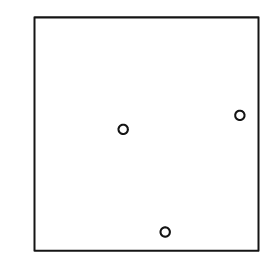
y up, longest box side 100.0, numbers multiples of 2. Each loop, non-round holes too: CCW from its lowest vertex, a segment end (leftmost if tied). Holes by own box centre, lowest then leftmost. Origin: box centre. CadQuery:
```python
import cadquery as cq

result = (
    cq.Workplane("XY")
    .moveTo(-48.0, -50.0)
    .lineTo(48.0, -50.0)
    .lineTo(48.0, 50.0)
    .lineTo(-48.0, 50.0)
    .close()
    .moveTo(8.0, -42.0)
    .circle(2.0)
    .moveTo(-10.0, 2.0)
    .circle(2.0)
    .moveTo(40.0, 8.0)
    .circle(2.0)
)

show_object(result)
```